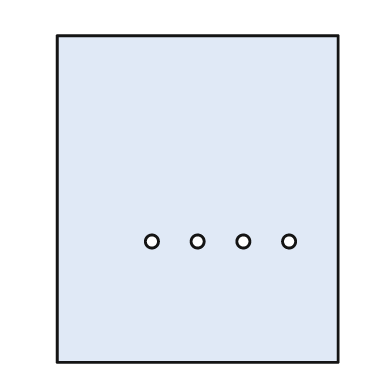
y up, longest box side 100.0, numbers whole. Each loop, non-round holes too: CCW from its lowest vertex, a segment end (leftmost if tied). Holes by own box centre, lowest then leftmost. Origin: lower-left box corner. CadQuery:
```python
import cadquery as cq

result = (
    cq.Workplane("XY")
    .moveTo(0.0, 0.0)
    .lineTo(86.0, 0.0)
    .lineTo(86.0, 100.0)
    .lineTo(0.0, 100.0)
    .close()
    .moveTo(29.0, 37.0)
    .circle(2.0)
    .moveTo(43.0, 37.0)
    .circle(2.0)
    .moveTo(57.0, 37.0)
    .circle(2.0)
    .moveTo(71.0, 37.0)
    .circle(2.0)
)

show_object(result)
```